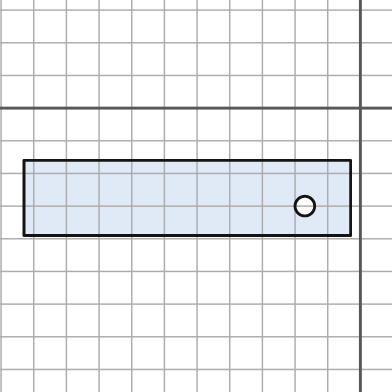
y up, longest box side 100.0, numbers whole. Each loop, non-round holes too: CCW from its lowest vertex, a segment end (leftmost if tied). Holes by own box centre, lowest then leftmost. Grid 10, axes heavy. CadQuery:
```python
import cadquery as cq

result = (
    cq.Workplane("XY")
    .moveTo(-103.0, -39.0)
    .lineTo(-3.0, -39.0)
    .lineTo(-3.0, -16.0)
    .lineTo(-103.0, -16.0)
    .close()
    .moveTo(-17.0, -30.0)
    .circle(3.0)
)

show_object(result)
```